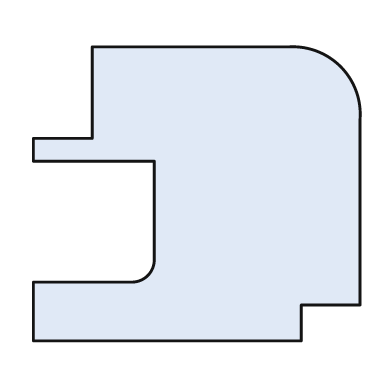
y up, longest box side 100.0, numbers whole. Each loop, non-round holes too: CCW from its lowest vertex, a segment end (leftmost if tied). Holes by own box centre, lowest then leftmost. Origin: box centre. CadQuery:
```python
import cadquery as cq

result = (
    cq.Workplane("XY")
    .moveTo(-50.0, -45.0)
    .lineTo(32.0, -45.0)
    .lineTo(32.0, -34.0)
    .lineTo(50.0, -34.0)
    .lineTo(50.0, 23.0)
    .threePointArc((44.0, 39.0), (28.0, 45.0))
    .lineTo(-32.0, 45.0)
    .lineTo(-32.0, 17.0)
    .lineTo(-50.0, 17.0)
    .lineTo(-50.0, 10.0)
    .lineTo(-13.0, 10.0)
    .lineTo(-13.0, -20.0)
    .threePointArc((-15.0, -25.0), (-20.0, -27.0))
    .lineTo(-50.0, -27.0)
    .close()
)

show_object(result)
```